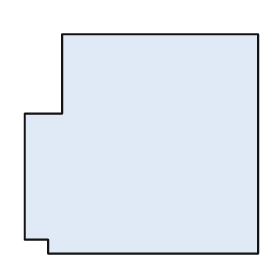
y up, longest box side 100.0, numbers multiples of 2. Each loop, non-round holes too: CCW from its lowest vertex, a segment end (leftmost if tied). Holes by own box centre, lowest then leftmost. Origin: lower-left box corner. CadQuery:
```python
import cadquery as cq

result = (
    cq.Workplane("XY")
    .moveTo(10.0, 0.0)
    .lineTo(100.0, 0.0)
    .lineTo(100.0, 94.0)
    .lineTo(16.0, 94.0)
    .lineTo(16.0, 60.0)
    .lineTo(0.0, 60.0)
    .lineTo(0.0, 6.0)
    .lineTo(10.0, 6.0)
    .close()
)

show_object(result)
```